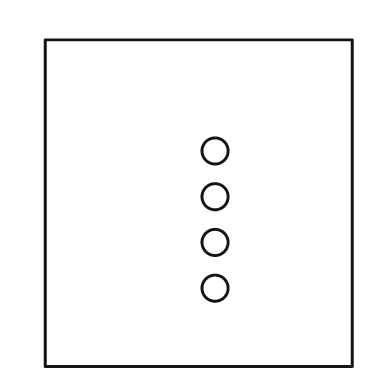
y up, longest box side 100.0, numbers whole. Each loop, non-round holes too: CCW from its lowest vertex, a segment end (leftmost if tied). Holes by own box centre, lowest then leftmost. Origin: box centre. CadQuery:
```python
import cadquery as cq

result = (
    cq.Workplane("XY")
    .moveTo(-47.0, -50.0)
    .lineTo(47.0, -50.0)
    .lineTo(47.0, 50.0)
    .lineTo(-47.0, 50.0)
    .close()
    .moveTo(5.0, -26.0)
    .circle(4.0)
    .moveTo(5.0, -12.0)
    .circle(4.0)
    .moveTo(5.0, 2.0)
    .circle(4.0)
    .moveTo(5.0, 16.0)
    .circle(4.0)
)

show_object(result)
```